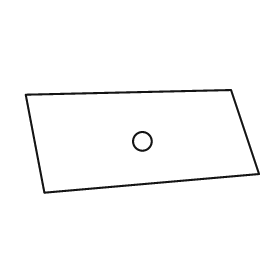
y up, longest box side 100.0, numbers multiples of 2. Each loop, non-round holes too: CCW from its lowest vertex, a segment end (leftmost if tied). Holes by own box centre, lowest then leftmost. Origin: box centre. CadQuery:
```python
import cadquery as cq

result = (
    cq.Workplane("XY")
    .moveTo(-42.0, -22.0)
    .lineTo(50.0, -14.0)
    .lineTo(38.0, 22.0)
    .lineTo(-50.0, 20.0)
    .close()
    .moveTo(0.0, 0.0)
    .circle(4.0)
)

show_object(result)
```